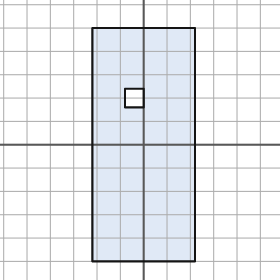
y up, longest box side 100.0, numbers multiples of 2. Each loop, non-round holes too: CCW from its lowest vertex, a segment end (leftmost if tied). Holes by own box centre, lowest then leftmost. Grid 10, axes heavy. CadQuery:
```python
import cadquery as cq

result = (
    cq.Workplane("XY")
    .moveTo(-22.0, -50.0)
    .lineTo(22.0, -50.0)
    .lineTo(22.0, 50.0)
    .lineTo(-22.0, 50.0)
    .close()
    .moveTo(-8.0, 16.0)
    .lineTo(0.0, 16.0)
    .lineTo(0.0, 24.0)
    .lineTo(-8.0, 24.0)
    .close()
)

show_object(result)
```